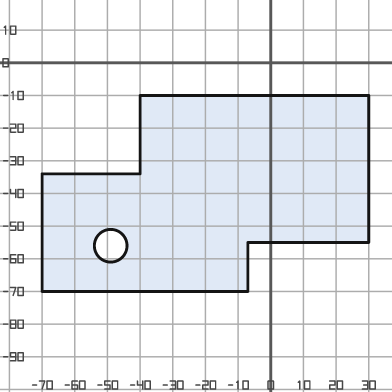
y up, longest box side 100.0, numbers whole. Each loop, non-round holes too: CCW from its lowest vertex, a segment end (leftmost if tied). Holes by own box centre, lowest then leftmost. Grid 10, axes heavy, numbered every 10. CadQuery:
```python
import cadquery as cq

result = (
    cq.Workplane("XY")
    .moveTo(-70.0, -70.0)
    .lineTo(-7.0, -70.0)
    .lineTo(-7.0, -55.0)
    .lineTo(30.0, -55.0)
    .lineTo(30.0, -10.0)
    .lineTo(-40.0, -10.0)
    .lineTo(-40.0, -34.0)
    .lineTo(-70.0, -34.0)
    .close()
    .moveTo(-49.0, -56.0)
    .circle(5.0)
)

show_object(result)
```